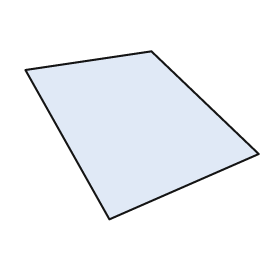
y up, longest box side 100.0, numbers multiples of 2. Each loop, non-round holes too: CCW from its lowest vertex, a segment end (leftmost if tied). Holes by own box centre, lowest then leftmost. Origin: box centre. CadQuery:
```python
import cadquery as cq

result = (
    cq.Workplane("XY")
    .moveTo(-14.0, -36.0)
    .lineTo(50.0, -8.0)
    .lineTo(4.0, 36.0)
    .lineTo(-50.0, 28.0)
    .close()
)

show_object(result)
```